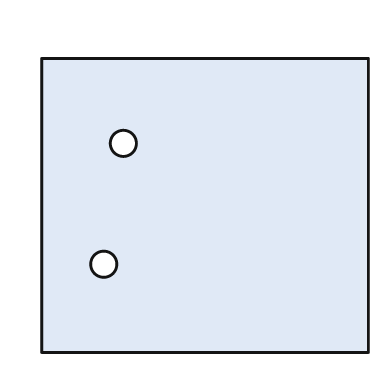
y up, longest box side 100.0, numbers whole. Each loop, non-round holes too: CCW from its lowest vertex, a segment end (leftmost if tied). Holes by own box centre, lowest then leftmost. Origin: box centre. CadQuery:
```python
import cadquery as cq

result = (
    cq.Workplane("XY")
    .moveTo(-50.0, -45.0)
    .lineTo(50.0, -45.0)
    .lineTo(50.0, 45.0)
    .lineTo(-50.0, 45.0)
    .close()
    .moveTo(-31.0, -18.0)
    .circle(4.0)
    .moveTo(-25.0, 19.0)
    .circle(4.0)
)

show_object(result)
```